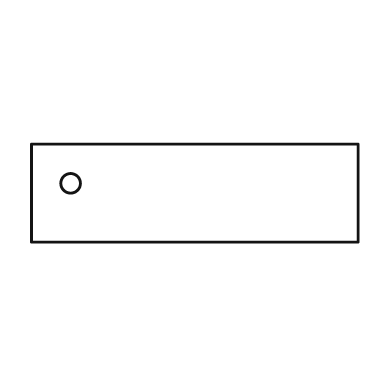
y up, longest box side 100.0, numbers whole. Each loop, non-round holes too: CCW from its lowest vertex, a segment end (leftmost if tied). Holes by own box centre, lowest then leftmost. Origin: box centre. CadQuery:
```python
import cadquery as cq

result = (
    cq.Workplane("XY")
    .moveTo(-50.0, -15.0)
    .lineTo(50.0, -15.0)
    .lineTo(50.0, 15.0)
    .lineTo(-50.0, 15.0)
    .close()
    .moveTo(-38.0, 3.0)
    .circle(3.0)
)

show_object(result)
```